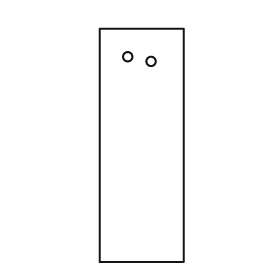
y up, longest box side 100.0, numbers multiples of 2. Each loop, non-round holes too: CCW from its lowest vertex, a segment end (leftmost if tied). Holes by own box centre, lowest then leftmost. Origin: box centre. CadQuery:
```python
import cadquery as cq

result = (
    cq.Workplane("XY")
    .moveTo(-18.0, -50.0)
    .lineTo(18.0, -50.0)
    .lineTo(18.0, 50.0)
    .lineTo(-18.0, 50.0)
    .close()
    .moveTo(4.0, 36.0)
    .circle(2.0)
    .moveTo(-6.0, 38.0)
    .circle(2.0)
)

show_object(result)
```